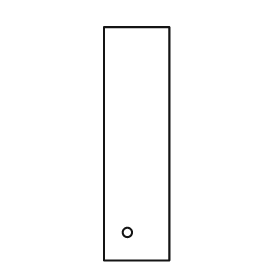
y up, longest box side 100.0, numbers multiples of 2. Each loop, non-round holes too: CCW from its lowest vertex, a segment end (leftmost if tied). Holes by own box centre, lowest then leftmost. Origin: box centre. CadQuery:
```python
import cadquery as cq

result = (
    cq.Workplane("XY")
    .moveTo(-14.0, -50.0)
    .lineTo(14.0, -50.0)
    .lineTo(14.0, 50.0)
    .lineTo(-14.0, 50.0)
    .close()
    .moveTo(-4.0, -38.0)
    .circle(2.0)
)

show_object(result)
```